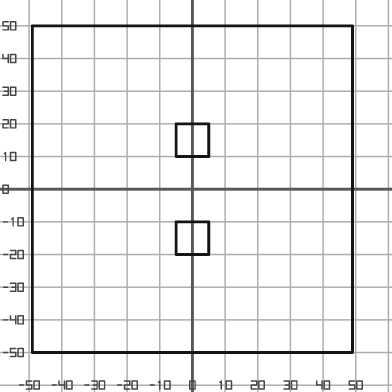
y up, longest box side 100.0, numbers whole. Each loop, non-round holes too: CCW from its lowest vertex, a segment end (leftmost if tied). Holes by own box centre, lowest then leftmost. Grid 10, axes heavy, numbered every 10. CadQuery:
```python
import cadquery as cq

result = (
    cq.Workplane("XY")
    .moveTo(-49.0, -50.0)
    .lineTo(49.0, -50.0)
    .lineTo(49.0, 50.0)
    .lineTo(-49.0, 50.0)
    .close()
    .moveTo(-5.0, -20.0)
    .lineTo(5.0, -20.0)
    .lineTo(5.0, -10.0)
    .lineTo(-5.0, -10.0)
    .close()
    .moveTo(-5.0, 10.0)
    .lineTo(5.0, 10.0)
    .lineTo(5.0, 20.0)
    .lineTo(-5.0, 20.0)
    .close()
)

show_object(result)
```